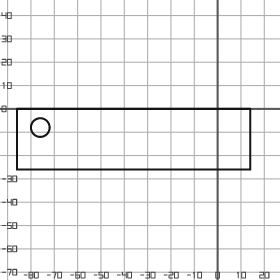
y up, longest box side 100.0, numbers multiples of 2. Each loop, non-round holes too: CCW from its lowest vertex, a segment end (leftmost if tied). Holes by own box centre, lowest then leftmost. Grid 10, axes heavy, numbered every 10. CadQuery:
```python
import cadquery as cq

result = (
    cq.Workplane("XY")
    .moveTo(-86.0, -26.0)
    .lineTo(14.0, -26.0)
    .lineTo(14.0, 0.0)
    .lineTo(-86.0, 0.0)
    .close()
    .moveTo(-76.0, -8.0)
    .circle(4.0)
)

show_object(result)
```